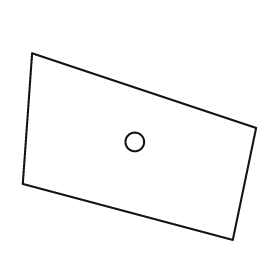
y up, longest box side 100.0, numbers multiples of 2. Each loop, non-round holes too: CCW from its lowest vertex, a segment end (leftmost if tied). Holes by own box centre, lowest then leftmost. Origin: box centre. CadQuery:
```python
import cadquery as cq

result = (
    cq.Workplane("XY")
    .moveTo(40.0, -40.0)
    .lineTo(50.0, 8.0)
    .lineTo(-46.0, 40.0)
    .lineTo(-50.0, -16.0)
    .close()
    .moveTo(-2.0, 2.0)
    .circle(4.0)
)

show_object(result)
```